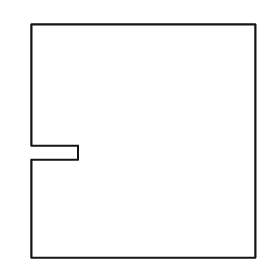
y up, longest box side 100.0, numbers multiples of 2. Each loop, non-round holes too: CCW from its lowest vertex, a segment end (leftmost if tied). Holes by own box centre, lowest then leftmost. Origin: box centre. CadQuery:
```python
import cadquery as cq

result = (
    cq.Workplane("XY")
    .moveTo(-48.0, -50.0)
    .lineTo(48.0, -50.0)
    .lineTo(48.0, 50.0)
    .lineTo(-48.0, 50.0)
    .lineTo(-48.0, -2.0)
    .lineTo(-28.0, -2.0)
    .lineTo(-28.0, -8.0)
    .lineTo(-48.0, -8.0)
    .close()
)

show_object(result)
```